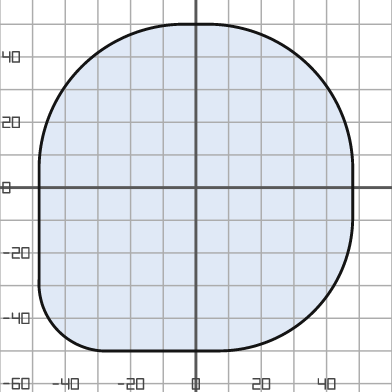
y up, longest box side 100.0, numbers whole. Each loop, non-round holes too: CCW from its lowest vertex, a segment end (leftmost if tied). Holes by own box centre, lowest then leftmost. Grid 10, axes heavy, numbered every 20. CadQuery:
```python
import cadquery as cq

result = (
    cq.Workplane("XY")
    .moveTo(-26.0, -50.0)
    .lineTo(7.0, -50.0)
    .threePointArc((36.0, -38.0), (48.0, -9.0))
    .lineTo(48.0, 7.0)
    .threePointArc((35.0, 37.0), (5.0, 50.0))
    .lineTo(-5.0, 50.0)
    .threePointArc((-35.0, 37.0), (-48.0, 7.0))
    .lineTo(-48.0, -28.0)
    .threePointArc((-42.0, -44.0), (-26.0, -50.0))
    .close()
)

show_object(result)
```